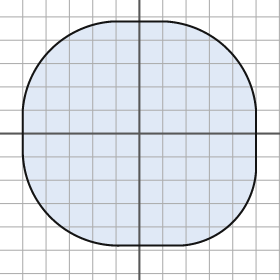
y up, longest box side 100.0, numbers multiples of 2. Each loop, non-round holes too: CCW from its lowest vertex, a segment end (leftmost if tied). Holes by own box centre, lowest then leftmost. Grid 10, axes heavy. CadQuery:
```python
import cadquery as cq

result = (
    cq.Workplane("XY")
    .moveTo(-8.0, -48.0)
    .lineTo(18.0, -48.0)
    .threePointArc((40.0, -38.0), (50.0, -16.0))
    .lineTo(50.0, 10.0)
    .threePointArc((38.0, 36.0), (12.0, 48.0))
    .lineTo(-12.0, 48.0)
    .threePointArc((-38.0, 36.0), (-50.0, 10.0))
    .lineTo(-50.0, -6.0)
    .threePointArc((-38.0, -36.0), (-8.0, -48.0))
    .close()
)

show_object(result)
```